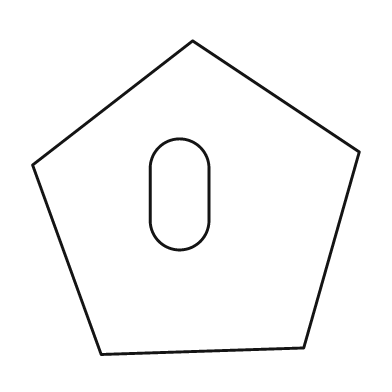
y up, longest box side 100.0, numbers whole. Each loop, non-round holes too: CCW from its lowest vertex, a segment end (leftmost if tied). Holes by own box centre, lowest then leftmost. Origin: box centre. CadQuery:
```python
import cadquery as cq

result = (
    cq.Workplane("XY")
    .moveTo(-29.0, -48.0)
    .lineTo(33.0, -46.0)
    .lineTo(50.0, 14.0)
    .lineTo(-1.0, 48.0)
    .lineTo(-50.0, 10.0)
    .close()
    .moveTo(-14.0, -7.0)
    .threePointArc((-5.0, -16.0), (4.0, -7.0))
    .lineTo(4.0, 9.0)
    .threePointArc((-5.0, 18.0), (-14.0, 9.0))
    .close()
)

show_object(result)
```